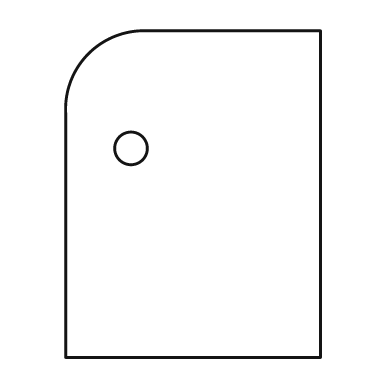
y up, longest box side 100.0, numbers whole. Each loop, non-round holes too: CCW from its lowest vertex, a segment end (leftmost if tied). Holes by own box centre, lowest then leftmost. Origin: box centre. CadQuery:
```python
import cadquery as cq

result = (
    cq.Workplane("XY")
    .moveTo(-39.0, -50.0)
    .lineTo(39.0, -50.0)
    .lineTo(39.0, 50.0)
    .lineTo(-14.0, 50.0)
    .threePointArc((-32.0, 43.0), (-39.0, 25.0))
    .close()
    .moveTo(-19.0, 14.0)
    .circle(5.0)
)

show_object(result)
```